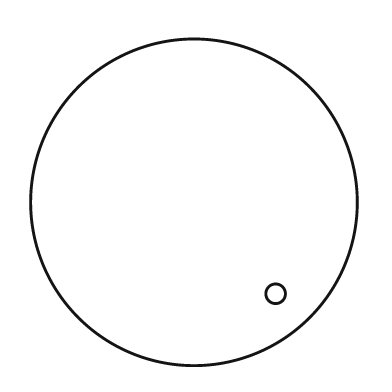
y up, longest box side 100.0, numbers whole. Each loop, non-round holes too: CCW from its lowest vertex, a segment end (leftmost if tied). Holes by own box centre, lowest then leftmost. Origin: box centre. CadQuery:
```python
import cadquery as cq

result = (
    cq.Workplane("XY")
    .moveTo(0.0, 0.0)
    .circle(50.0)
    .moveTo(25.0, -28.0)
    .circle(3.0)
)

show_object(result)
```